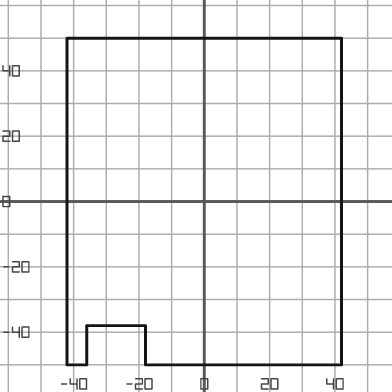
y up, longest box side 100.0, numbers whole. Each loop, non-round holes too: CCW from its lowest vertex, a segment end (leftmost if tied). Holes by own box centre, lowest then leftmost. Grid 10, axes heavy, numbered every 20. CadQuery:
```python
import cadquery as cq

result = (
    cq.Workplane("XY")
    .moveTo(-42.0, -50.0)
    .lineTo(-36.0, -50.0)
    .lineTo(-36.0, -38.0)
    .lineTo(-18.0, -38.0)
    .lineTo(-18.0, -50.0)
    .lineTo(42.0, -50.0)
    .lineTo(42.0, 50.0)
    .lineTo(-42.0, 50.0)
    .close()
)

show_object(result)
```